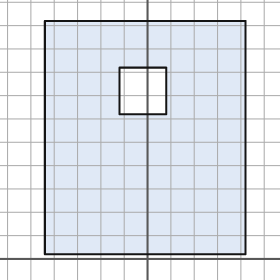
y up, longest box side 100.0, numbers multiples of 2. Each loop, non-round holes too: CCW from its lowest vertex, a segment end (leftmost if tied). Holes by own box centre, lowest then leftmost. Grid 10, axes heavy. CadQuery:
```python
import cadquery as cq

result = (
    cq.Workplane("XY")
    .moveTo(-44.0, 2.0)
    .lineTo(42.0, 2.0)
    .lineTo(42.0, 102.0)
    .lineTo(-44.0, 102.0)
    .close()
    .moveTo(-12.0, 62.0)
    .lineTo(8.0, 62.0)
    .lineTo(8.0, 82.0)
    .lineTo(-12.0, 82.0)
    .close()
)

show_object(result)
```